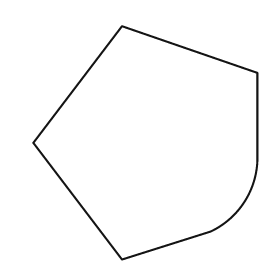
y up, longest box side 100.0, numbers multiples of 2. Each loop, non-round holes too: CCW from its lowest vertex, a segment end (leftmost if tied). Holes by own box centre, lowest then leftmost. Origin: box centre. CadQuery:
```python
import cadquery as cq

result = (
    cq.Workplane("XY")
    .moveTo(-10.0, -50.0)
    .lineTo(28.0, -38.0)
    .threePointArc((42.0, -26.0), (48.0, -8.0))
    .lineTo(48.0, 30.0)
    .lineTo(-10.0, 50.0)
    .lineTo(-48.0, 0.0)
    .close()
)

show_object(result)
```